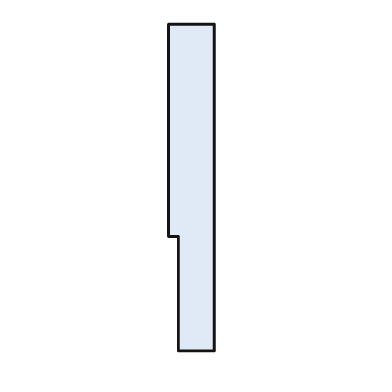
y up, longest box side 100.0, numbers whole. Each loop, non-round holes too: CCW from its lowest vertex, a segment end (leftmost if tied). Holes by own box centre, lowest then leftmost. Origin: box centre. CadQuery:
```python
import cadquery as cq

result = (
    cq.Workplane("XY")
    .moveTo(-4.0, -50.0)
    .lineTo(7.0, -50.0)
    .lineTo(7.0, 50.0)
    .lineTo(-7.0, 50.0)
    .lineTo(-7.0, -15.0)
    .lineTo(-4.0, -15.0)
    .close()
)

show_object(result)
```